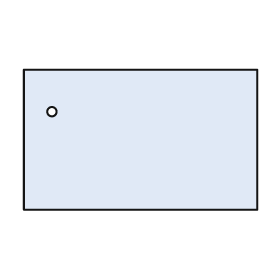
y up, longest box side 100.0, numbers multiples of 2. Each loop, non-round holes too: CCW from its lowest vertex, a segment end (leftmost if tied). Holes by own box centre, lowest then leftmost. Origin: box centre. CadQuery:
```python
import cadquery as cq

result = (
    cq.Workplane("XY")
    .moveTo(-50.0, -30.0)
    .lineTo(50.0, -30.0)
    .lineTo(50.0, 30.0)
    .lineTo(-50.0, 30.0)
    .close()
    .moveTo(-38.0, 12.0)
    .circle(2.0)
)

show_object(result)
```